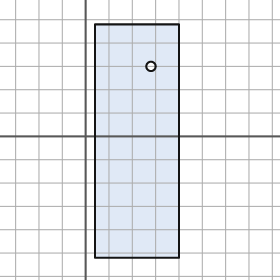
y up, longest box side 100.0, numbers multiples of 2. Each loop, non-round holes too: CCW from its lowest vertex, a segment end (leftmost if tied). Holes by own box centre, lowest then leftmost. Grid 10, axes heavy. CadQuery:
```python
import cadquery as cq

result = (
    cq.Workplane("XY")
    .moveTo(4.0, -52.0)
    .lineTo(40.0, -52.0)
    .lineTo(40.0, 48.0)
    .lineTo(4.0, 48.0)
    .close()
    .moveTo(28.0, 30.0)
    .circle(2.0)
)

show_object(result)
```